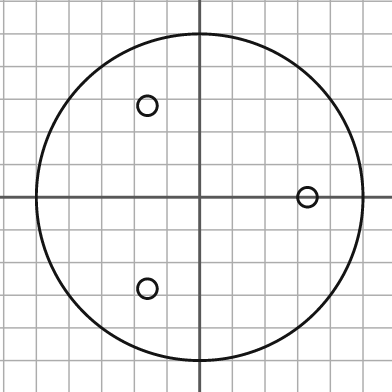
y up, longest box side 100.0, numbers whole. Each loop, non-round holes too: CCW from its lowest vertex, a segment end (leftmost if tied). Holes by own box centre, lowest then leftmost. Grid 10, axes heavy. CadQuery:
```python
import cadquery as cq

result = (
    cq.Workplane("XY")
    .moveTo(0.0, 0.0)
    .circle(50.0)
    .moveTo(-16.0, -28.0)
    .circle(3.0)
    .moveTo(33.0, 0.0)
    .circle(3.0)
    .moveTo(-16.0, 28.0)
    .circle(3.0)
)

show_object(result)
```